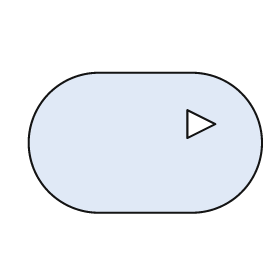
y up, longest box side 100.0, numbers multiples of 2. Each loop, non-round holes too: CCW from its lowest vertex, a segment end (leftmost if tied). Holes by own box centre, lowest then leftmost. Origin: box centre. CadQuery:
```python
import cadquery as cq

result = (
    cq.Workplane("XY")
    .moveTo(-20.0, -30.0)
    .lineTo(20.0, -30.0)
    .threePointArc((50.0, 0.0), (20.0, 30.0))
    .lineTo(-20.0, 30.0)
    .threePointArc((-50.0, 0.0), (-20.0, -30.0))
    .close()
    .moveTo(18.0, 2.0)
    .lineTo(30.0, 8.0)
    .lineTo(18.0, 14.0)
    .close()
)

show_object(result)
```